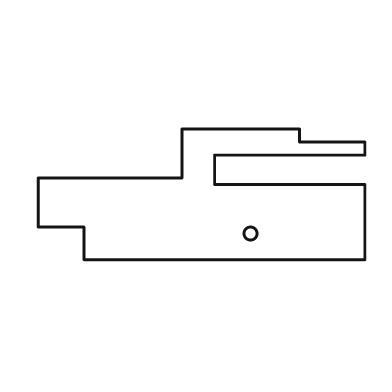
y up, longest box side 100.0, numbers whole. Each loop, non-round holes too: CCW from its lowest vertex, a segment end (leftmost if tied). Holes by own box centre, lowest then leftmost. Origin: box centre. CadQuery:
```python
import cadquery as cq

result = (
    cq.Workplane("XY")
    .moveTo(-36.0, -20.0)
    .lineTo(50.0, -20.0)
    .lineTo(50.0, 3.0)
    .lineTo(4.0, 3.0)
    .lineTo(4.0, 12.0)
    .lineTo(50.0, 12.0)
    .lineTo(50.0, 16.0)
    .lineTo(30.0, 16.0)
    .lineTo(30.0, 20.0)
    .lineTo(-6.0, 20.0)
    .lineTo(-6.0, 5.0)
    .lineTo(-50.0, 5.0)
    .lineTo(-50.0, -10.0)
    .lineTo(-36.0, -10.0)
    .close()
    .moveTo(15.0, -12.0)
    .circle(2.0)
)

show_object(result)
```